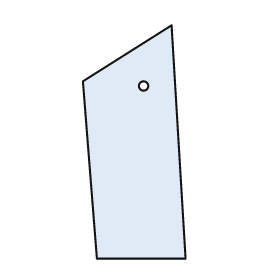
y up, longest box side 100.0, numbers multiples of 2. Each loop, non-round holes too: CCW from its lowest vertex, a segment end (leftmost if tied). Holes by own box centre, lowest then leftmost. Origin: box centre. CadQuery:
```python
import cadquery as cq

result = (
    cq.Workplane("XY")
    .moveTo(-16.0, -50.0)
    .lineTo(22.0, -50.0)
    .lineTo(16.0, 50.0)
    .lineTo(-22.0, 26.0)
    .close()
    .moveTo(4.0, 24.0)
    .circle(2.0)
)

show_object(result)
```